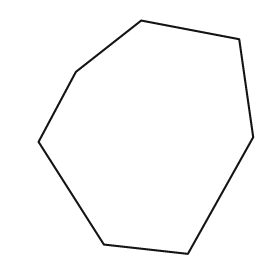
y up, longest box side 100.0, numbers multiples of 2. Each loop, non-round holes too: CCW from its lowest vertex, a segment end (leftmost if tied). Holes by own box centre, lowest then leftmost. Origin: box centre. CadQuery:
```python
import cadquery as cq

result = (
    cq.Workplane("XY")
    .moveTo(18.0, -50.0)
    .lineTo(46.0, 0.0)
    .lineTo(40.0, 42.0)
    .lineTo(-2.0, 50.0)
    .lineTo(-30.0, 28.0)
    .lineTo(-46.0, -2.0)
    .lineTo(-18.0, -46.0)
    .close()
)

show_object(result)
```